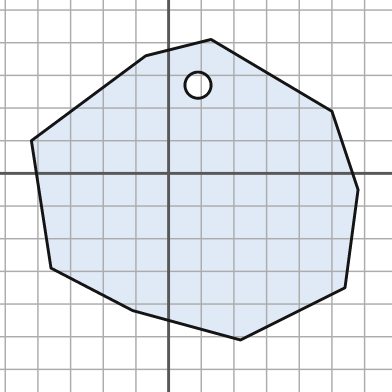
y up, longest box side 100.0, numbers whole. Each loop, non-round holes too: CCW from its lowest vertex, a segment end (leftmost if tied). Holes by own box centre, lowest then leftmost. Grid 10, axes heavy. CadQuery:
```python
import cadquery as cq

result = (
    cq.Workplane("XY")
    .moveTo(22.0, -51.0)
    .lineTo(54.0, -35.0)
    .lineTo(58.0, -5.0)
    .lineTo(50.0, 19.0)
    .lineTo(13.0, 41.0)
    .lineTo(-7.0, 36.0)
    .lineTo(-42.0, 10.0)
    .lineTo(-36.0, -29.0)
    .lineTo(-11.0, -42.0)
    .close()
    .moveTo(9.0, 27.0)
    .circle(4.0)
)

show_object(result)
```